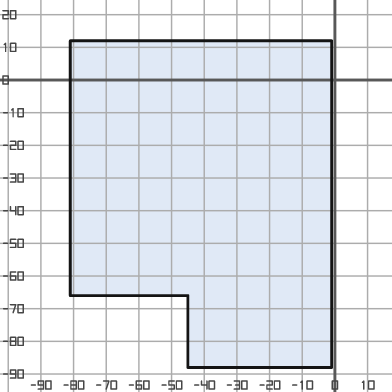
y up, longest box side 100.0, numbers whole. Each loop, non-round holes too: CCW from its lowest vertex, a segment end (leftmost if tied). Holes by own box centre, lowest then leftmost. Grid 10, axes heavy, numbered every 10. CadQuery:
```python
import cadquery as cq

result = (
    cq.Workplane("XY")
    .moveTo(-45.0, -88.0)
    .lineTo(-1.0, -88.0)
    .lineTo(-1.0, 12.0)
    .lineTo(-81.0, 12.0)
    .lineTo(-81.0, -66.0)
    .lineTo(-45.0, -66.0)
    .close()
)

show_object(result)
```